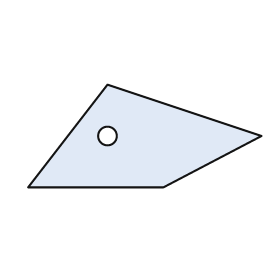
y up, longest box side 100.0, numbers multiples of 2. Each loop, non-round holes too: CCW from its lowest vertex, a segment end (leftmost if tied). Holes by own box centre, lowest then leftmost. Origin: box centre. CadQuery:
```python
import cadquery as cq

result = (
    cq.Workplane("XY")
    .moveTo(-50.0, -22.0)
    .lineTo(8.0, -22.0)
    .lineTo(50.0, 0.0)
    .lineTo(-16.0, 22.0)
    .close()
    .moveTo(-16.0, 0.0)
    .circle(4.0)
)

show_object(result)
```